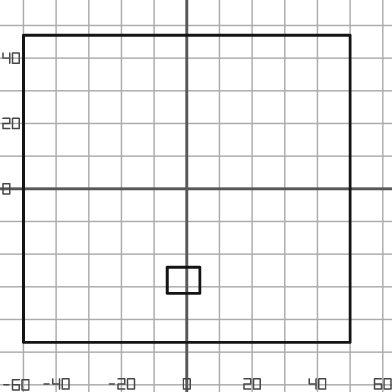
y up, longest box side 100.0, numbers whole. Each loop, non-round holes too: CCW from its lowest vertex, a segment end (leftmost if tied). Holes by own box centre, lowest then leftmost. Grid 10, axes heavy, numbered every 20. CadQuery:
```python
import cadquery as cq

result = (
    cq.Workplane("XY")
    .moveTo(-50.0, -47.0)
    .lineTo(50.0, -47.0)
    .lineTo(50.0, 47.0)
    .lineTo(-50.0, 47.0)
    .close()
    .moveTo(-6.0, -32.0)
    .lineTo(4.0, -32.0)
    .lineTo(4.0, -24.0)
    .lineTo(-6.0, -24.0)
    .close()
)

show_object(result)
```